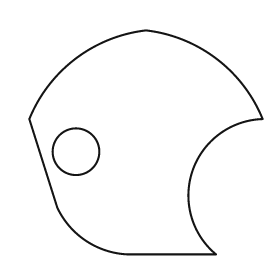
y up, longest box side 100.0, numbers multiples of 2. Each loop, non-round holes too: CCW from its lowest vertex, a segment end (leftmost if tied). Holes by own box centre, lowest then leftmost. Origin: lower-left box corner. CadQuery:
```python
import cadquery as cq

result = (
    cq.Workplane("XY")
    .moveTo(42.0, 0.0)
    .lineTo(80.0, 0.0)
    .threePointArc((70.0, 36.0), (100.0, 58.0))
    .threePointArc((80.0, 84.0), (50.0, 96.0))
    .threePointArc((20.0, 84.0), (0.0, 58.0))
    .lineTo(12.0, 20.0)
    .threePointArc((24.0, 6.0), (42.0, 0.0))
    .close()
    .moveTo(20.0, 44.0)
    .circle(10.0)
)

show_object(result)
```